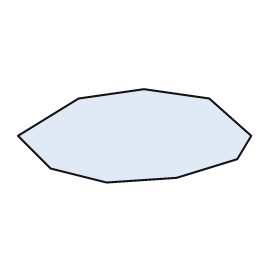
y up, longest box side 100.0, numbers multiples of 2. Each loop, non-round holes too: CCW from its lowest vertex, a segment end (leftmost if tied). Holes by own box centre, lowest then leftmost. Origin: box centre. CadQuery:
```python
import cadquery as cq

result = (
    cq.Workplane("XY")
    .moveTo(-12.0, -20.0)
    .lineTo(18.0, -18.0)
    .lineTo(44.0, -10.0)
    .lineTo(50.0, 0.0)
    .lineTo(32.0, 16.0)
    .lineTo(4.0, 20.0)
    .lineTo(-24.0, 16.0)
    .lineTo(-50.0, 0.0)
    .lineTo(-36.0, -14.0)
    .close()
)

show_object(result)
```